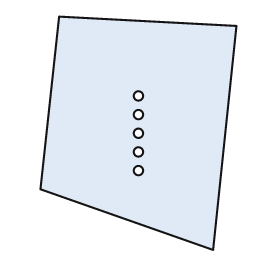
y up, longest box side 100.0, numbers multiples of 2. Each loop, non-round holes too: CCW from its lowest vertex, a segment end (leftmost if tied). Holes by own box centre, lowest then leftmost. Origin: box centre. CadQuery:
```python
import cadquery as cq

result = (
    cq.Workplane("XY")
    .moveTo(32.0, -50.0)
    .lineTo(42.0, 46.0)
    .lineTo(-34.0, 50.0)
    .lineTo(-42.0, -24.0)
    .close()
    .moveTo(0.0, -16.0)
    .circle(2.0)
    .moveTo(0.0, -8.0)
    .circle(2.0)
    .moveTo(0.0, 0.0)
    .circle(2.0)
    .moveTo(0.0, 8.0)
    .circle(2.0)
    .moveTo(0.0, 16.0)
    .circle(2.0)
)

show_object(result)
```